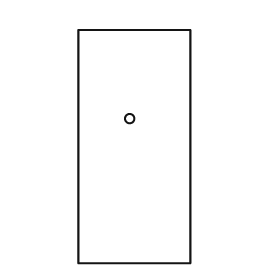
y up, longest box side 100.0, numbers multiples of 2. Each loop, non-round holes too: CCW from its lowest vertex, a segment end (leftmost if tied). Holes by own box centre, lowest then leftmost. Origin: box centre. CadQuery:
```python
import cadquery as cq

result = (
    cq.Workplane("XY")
    .moveTo(-24.0, -50.0)
    .lineTo(24.0, -50.0)
    .lineTo(24.0, 50.0)
    .lineTo(-24.0, 50.0)
    .close()
    .moveTo(-2.0, 12.0)
    .circle(2.0)
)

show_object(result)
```